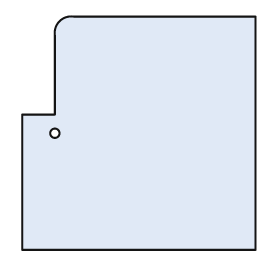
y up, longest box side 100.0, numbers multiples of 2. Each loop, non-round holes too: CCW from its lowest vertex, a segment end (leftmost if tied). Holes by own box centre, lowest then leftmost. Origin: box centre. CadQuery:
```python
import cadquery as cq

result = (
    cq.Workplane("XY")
    .moveTo(-50.0, -50.0)
    .lineTo(50.0, -50.0)
    .lineTo(50.0, 50.0)
    .lineTo(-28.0, 50.0)
    .threePointArc((-34.0, 48.0), (-36.0, 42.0))
    .lineTo(-36.0, 8.0)
    .lineTo(-50.0, 8.0)
    .close()
    .moveTo(-36.0, 0.0)
    .circle(2.0)
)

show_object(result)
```